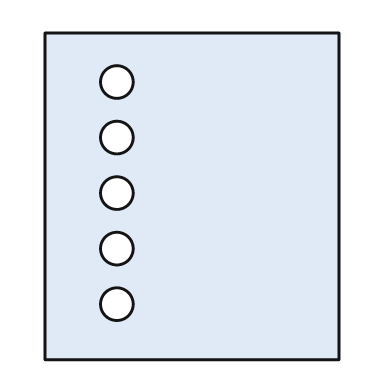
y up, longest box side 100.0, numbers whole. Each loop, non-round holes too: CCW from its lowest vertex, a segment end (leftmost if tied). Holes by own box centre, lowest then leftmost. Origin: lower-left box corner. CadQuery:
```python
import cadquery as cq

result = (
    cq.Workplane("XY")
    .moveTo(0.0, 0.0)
    .lineTo(90.0, 0.0)
    .lineTo(90.0, 100.0)
    .lineTo(0.0, 100.0)
    .close()
    .moveTo(22.0, 17.0)
    .circle(5.0)
    .moveTo(22.0, 34.0)
    .circle(5.0)
    .moveTo(22.0, 51.0)
    .circle(5.0)
    .moveTo(22.0, 68.0)
    .circle(5.0)
    .moveTo(22.0, 85.0)
    .circle(5.0)
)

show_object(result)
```